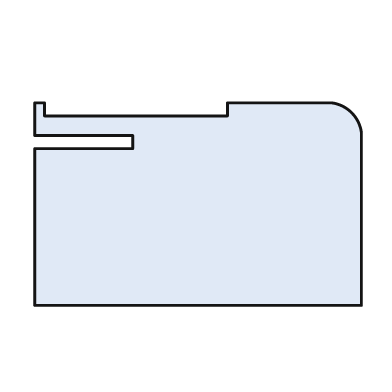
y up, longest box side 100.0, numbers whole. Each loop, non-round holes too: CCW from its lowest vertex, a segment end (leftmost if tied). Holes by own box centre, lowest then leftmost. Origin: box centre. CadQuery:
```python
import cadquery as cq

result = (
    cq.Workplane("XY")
    .moveTo(-50.0, -31.0)
    .lineTo(50.0, -31.0)
    .lineTo(50.0, 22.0)
    .threePointArc((47.0, 28.0), (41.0, 31.0))
    .lineTo(9.0, 31.0)
    .lineTo(9.0, 27.0)
    .lineTo(-47.0, 27.0)
    .lineTo(-47.0, 31.0)
    .lineTo(-50.0, 31.0)
    .lineTo(-50.0, 21.0)
    .lineTo(-20.0, 21.0)
    .lineTo(-20.0, 17.0)
    .lineTo(-50.0, 17.0)
    .close()
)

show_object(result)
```